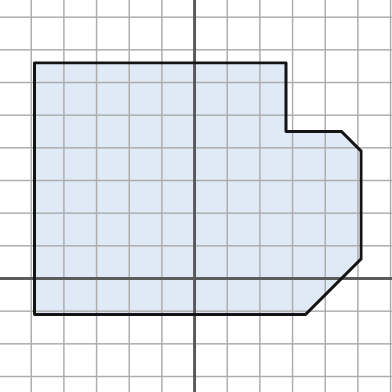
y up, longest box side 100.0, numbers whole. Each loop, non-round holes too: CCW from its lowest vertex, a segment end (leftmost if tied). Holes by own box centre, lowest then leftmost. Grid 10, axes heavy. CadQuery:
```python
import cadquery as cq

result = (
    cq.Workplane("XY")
    .moveTo(-49.0, -11.0)
    .lineTo(34.0, -11.0)
    .lineTo(51.0, 6.0)
    .lineTo(51.0, 39.0)
    .lineTo(45.0, 45.0)
    .lineTo(28.0, 45.0)
    .lineTo(28.0, 66.0)
    .lineTo(-49.0, 66.0)
    .close()
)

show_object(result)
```